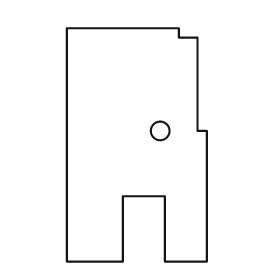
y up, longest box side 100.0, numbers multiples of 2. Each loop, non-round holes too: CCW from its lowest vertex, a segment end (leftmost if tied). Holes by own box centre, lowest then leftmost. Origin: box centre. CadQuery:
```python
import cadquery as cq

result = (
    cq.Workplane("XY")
    .moveTo(-30.0, -50.0)
    .lineTo(-6.0, -50.0)
    .lineTo(-6.0, -22.0)
    .lineTo(12.0, -22.0)
    .lineTo(12.0, -50.0)
    .lineTo(30.0, -50.0)
    .lineTo(30.0, 6.0)
    .lineTo(26.0, 6.0)
    .lineTo(26.0, 46.0)
    .lineTo(18.0, 46.0)
    .lineTo(18.0, 50.0)
    .lineTo(-30.0, 50.0)
    .close()
    .moveTo(10.0, 6.0)
    .circle(4.0)
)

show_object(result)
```